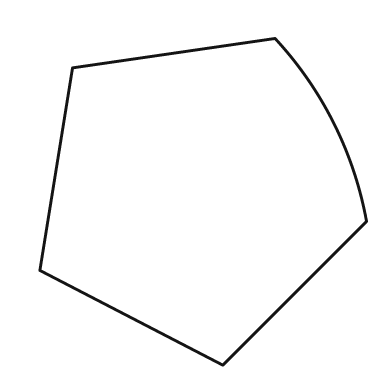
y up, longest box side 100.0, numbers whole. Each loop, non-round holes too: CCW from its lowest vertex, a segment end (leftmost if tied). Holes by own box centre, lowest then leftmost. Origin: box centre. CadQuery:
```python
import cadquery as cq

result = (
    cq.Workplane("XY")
    .moveTo(6.0, -50.0)
    .lineTo(50.0, -6.0)
    .threePointArc((40.0, 24.0), (22.0, 50.0))
    .lineTo(-40.0, 41.0)
    .lineTo(-50.0, -21.0)
    .close()
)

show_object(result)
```